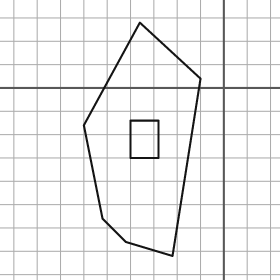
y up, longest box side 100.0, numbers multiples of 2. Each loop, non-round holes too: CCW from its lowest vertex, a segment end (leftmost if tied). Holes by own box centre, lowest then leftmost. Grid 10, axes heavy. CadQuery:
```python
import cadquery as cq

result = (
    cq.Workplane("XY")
    .moveTo(-22.0, -72.0)
    .lineTo(-10.0, 4.0)
    .lineTo(-36.0, 28.0)
    .lineTo(-60.0, -16.0)
    .lineTo(-52.0, -56.0)
    .lineTo(-42.0, -66.0)
    .close()
    .moveTo(-40.0, -30.0)
    .lineTo(-28.0, -30.0)
    .lineTo(-28.0, -14.0)
    .lineTo(-40.0, -14.0)
    .close()
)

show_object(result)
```